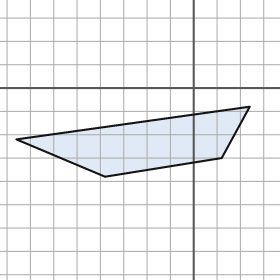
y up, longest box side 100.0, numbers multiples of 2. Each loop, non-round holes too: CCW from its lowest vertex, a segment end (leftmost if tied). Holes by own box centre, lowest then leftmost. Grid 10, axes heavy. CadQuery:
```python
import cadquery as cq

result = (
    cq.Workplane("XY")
    .moveTo(-38.0, -38.0)
    .lineTo(12.0, -30.0)
    .lineTo(24.0, -8.0)
    .lineTo(-76.0, -22.0)
    .close()
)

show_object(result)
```